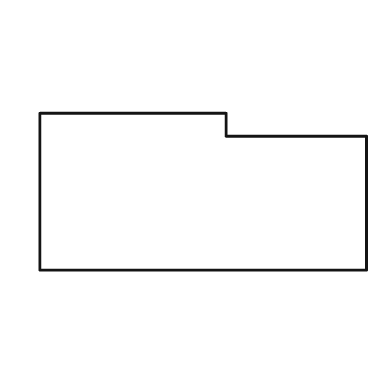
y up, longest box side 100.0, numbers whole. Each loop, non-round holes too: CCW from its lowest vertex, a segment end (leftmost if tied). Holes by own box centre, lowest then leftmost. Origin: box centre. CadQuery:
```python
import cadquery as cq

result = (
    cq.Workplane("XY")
    .moveTo(-50.0, -24.0)
    .lineTo(50.0, -24.0)
    .lineTo(50.0, 17.0)
    .lineTo(7.0, 17.0)
    .lineTo(7.0, 24.0)
    .lineTo(-50.0, 24.0)
    .close()
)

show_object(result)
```